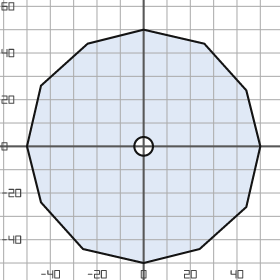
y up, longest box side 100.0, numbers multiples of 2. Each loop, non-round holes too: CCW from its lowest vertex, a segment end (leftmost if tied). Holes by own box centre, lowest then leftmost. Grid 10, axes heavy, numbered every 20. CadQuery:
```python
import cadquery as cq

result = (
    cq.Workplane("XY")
    .moveTo(0.0, -50.0)
    .lineTo(24.0, -44.0)
    .lineTo(44.0, -26.0)
    .lineTo(50.0, 0.0)
    .lineTo(44.0, 24.0)
    .lineTo(26.0, 44.0)
    .lineTo(0.0, 50.0)
    .lineTo(-24.0, 44.0)
    .lineTo(-44.0, 26.0)
    .lineTo(-50.0, 0.0)
    .lineTo(-44.0, -24.0)
    .lineTo(-26.0, -44.0)
    .close()
    .moveTo(0.0, 0.0)
    .circle(4.0)
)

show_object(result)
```